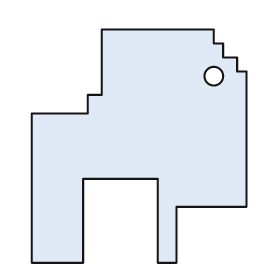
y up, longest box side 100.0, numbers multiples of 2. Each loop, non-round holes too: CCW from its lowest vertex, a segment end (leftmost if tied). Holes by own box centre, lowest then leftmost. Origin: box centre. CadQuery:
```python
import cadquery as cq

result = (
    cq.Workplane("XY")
    .moveTo(-46.0, -50.0)
    .lineTo(-24.0, -50.0)
    .lineTo(-24.0, -14.0)
    .lineTo(8.0, -14.0)
    .lineTo(8.0, -50.0)
    .lineTo(16.0, -50.0)
    .lineTo(16.0, -26.0)
    .lineTo(46.0, -26.0)
    .lineTo(46.0, 32.0)
    .lineTo(42.0, 32.0)
    .lineTo(42.0, 38.0)
    .lineTo(36.0, 38.0)
    .lineTo(36.0, 44.0)
    .lineTo(32.0, 44.0)
    .lineTo(32.0, 50.0)
    .lineTo(-16.0, 50.0)
    .lineTo(-16.0, 22.0)
    .lineTo(-22.0, 22.0)
    .lineTo(-22.0, 14.0)
    .lineTo(-46.0, 14.0)
    .close()
    .moveTo(32.0, 30.0)
    .circle(4.0)
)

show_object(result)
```